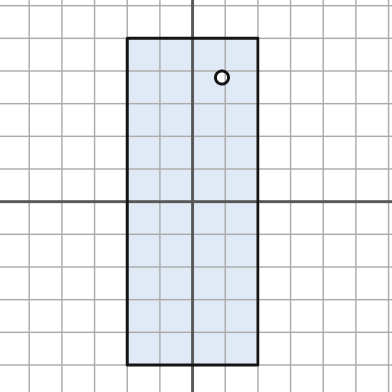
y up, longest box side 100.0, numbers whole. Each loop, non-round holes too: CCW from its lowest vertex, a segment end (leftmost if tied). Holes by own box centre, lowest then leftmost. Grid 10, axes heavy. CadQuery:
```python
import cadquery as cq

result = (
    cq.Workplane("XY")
    .moveTo(-20.0, -50.0)
    .lineTo(20.0, -50.0)
    .lineTo(20.0, 50.0)
    .lineTo(-20.0, 50.0)
    .close()
    .moveTo(9.0, 38.0)
    .circle(2.0)
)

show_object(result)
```